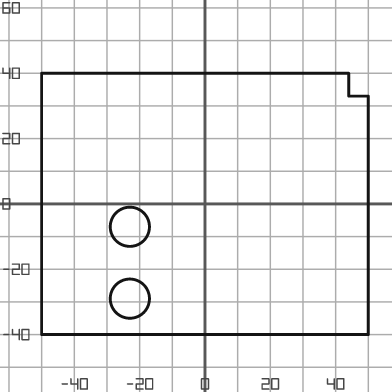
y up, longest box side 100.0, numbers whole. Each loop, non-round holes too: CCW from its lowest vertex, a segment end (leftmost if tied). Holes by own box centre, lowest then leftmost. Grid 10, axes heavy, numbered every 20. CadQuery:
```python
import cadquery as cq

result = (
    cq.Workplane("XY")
    .moveTo(-50.0, -40.0)
    .lineTo(50.0, -40.0)
    .lineTo(50.0, 33.0)
    .lineTo(44.0, 33.0)
    .lineTo(44.0, 40.0)
    .lineTo(-50.0, 40.0)
    .close()
    .moveTo(-23.0, -29.0)
    .circle(6.0)
    .moveTo(-23.0, -7.0)
    .circle(6.0)
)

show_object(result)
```